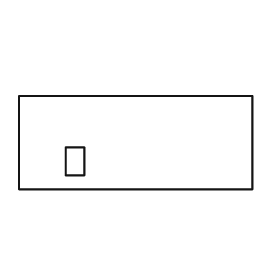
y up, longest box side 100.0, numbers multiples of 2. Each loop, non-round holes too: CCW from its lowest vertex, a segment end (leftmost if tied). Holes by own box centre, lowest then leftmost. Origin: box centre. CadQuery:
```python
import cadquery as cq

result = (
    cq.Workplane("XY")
    .moveTo(-50.0, -20.0)
    .lineTo(50.0, -20.0)
    .lineTo(50.0, 20.0)
    .lineTo(-50.0, 20.0)
    .close()
    .moveTo(-30.0, -14.0)
    .lineTo(-22.0, -14.0)
    .lineTo(-22.0, -2.0)
    .lineTo(-30.0, -2.0)
    .close()
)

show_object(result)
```